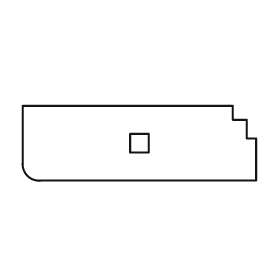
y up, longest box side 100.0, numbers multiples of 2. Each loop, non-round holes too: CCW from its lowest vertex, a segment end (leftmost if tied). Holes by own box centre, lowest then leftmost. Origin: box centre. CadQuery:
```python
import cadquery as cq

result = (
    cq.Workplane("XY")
    .moveTo(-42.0, -16.0)
    .lineTo(50.0, -16.0)
    .lineTo(50.0, 2.0)
    .lineTo(46.0, 2.0)
    .lineTo(46.0, 10.0)
    .lineTo(40.0, 10.0)
    .lineTo(40.0, 16.0)
    .lineTo(-50.0, 16.0)
    .lineTo(-50.0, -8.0)
    .threePointArc((-48.0, -14.0), (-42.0, -16.0))
    .close()
    .moveTo(-4.0, -4.0)
    .lineTo(4.0, -4.0)
    .lineTo(4.0, 4.0)
    .lineTo(-4.0, 4.0)
    .close()
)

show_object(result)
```